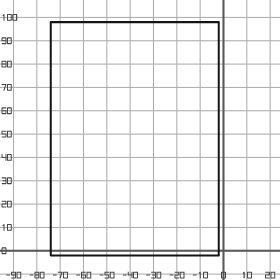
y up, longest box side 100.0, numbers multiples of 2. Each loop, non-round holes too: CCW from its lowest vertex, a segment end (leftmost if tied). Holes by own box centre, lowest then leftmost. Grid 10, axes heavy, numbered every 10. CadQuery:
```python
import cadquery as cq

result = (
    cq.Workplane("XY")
    .moveTo(-74.0, -2.0)
    .lineTo(-2.0, -2.0)
    .lineTo(-2.0, 98.0)
    .lineTo(-74.0, 98.0)
    .close()
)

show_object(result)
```